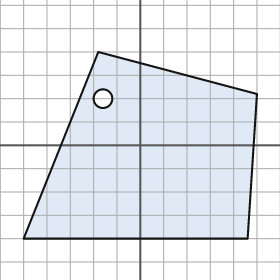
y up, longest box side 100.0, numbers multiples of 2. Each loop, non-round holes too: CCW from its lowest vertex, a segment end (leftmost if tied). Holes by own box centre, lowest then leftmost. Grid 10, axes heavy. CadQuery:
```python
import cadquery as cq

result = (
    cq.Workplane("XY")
    .moveTo(-50.0, -40.0)
    .lineTo(46.0, -40.0)
    .lineTo(50.0, 22.0)
    .lineTo(-18.0, 40.0)
    .close()
    .moveTo(-16.0, 20.0)
    .circle(4.0)
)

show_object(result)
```